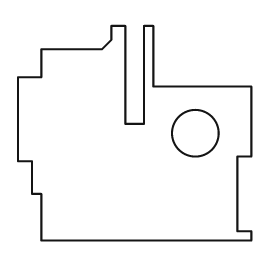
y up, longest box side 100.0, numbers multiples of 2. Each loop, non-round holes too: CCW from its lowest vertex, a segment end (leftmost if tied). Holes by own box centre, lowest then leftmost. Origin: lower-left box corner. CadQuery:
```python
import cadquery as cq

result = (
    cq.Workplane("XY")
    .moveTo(10.0, 0.0)
    .lineTo(100.0, 0.0)
    .lineTo(100.0, 4.0)
    .lineTo(94.0, 4.0)
    .lineTo(94.0, 36.0)
    .lineTo(100.0, 36.0)
    .lineTo(100.0, 66.0)
    .lineTo(58.0, 66.0)
    .lineTo(58.0, 92.0)
    .lineTo(54.0, 92.0)
    .lineTo(54.0, 50.0)
    .lineTo(46.0, 50.0)
    .lineTo(46.0, 92.0)
    .lineTo(40.0, 92.0)
    .lineTo(40.0, 86.0)
    .lineTo(36.0, 82.0)
    .lineTo(10.0, 82.0)
    .lineTo(10.0, 70.0)
    .lineTo(0.0, 70.0)
    .lineTo(0.0, 34.0)
    .lineTo(6.0, 34.0)
    .lineTo(6.0, 20.0)
    .lineTo(10.0, 20.0)
    .close()
    .moveTo(76.0, 46.0)
    .circle(10.0)
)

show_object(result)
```